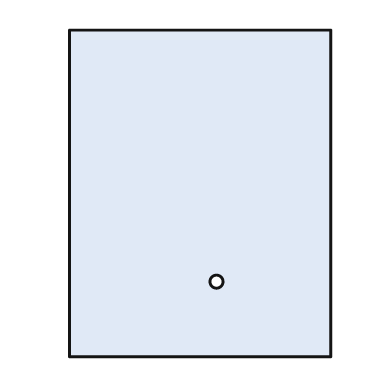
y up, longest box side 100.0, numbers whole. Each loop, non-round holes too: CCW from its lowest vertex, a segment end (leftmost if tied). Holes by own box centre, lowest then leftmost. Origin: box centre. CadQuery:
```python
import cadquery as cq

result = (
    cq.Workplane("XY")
    .moveTo(-40.0, -50.0)
    .lineTo(40.0, -50.0)
    .lineTo(40.0, 50.0)
    .lineTo(-40.0, 50.0)
    .close()
    .moveTo(5.0, -27.0)
    .circle(2.0)
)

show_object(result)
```